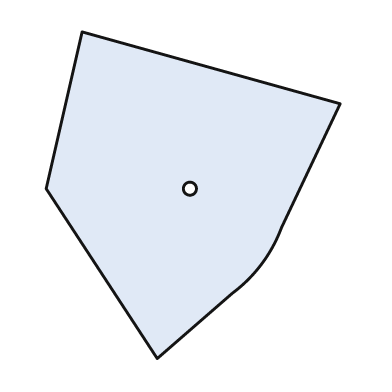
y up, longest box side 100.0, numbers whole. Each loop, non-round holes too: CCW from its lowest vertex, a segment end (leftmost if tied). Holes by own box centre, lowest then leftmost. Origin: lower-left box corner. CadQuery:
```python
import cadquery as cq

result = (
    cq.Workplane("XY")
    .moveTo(34.0, 0.0)
    .lineTo(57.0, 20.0)
    .threePointArc((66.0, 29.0), (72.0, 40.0))
    .lineTo(90.0, 78.0)
    .lineTo(11.0, 100.0)
    .lineTo(0.0, 52.0)
    .close()
    .moveTo(44.0, 52.0)
    .circle(2.0)
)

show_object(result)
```